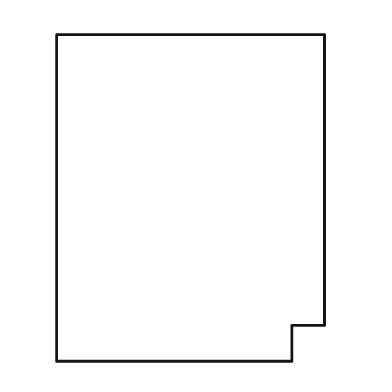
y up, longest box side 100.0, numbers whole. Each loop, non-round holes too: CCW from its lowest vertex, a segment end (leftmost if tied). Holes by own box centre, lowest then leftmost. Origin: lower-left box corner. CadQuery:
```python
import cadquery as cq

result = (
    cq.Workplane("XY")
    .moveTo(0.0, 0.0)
    .lineTo(72.0, 0.0)
    .lineTo(72.0, 11.0)
    .lineTo(82.0, 11.0)
    .lineTo(82.0, 100.0)
    .lineTo(0.0, 100.0)
    .close()
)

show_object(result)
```